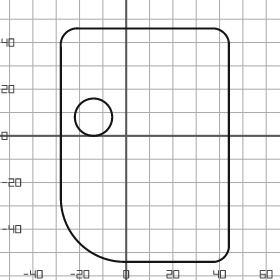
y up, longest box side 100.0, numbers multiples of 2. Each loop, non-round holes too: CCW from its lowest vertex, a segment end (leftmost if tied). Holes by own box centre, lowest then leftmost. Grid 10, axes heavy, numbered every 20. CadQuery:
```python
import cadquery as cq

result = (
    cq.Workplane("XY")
    .moveTo(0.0, -54.0)
    .lineTo(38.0, -54.0)
    .threePointArc((42.0, -52.0), (44.0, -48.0))
    .lineTo(44.0, 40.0)
    .threePointArc((42.0, 44.0), (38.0, 46.0))
    .lineTo(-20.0, 46.0)
    .threePointArc((-26.0, 44.0), (-28.0, 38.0))
    .lineTo(-28.0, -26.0)
    .threePointArc((-20.0, -46.0), (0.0, -54.0))
    .close()
    .moveTo(-14.0, 8.0)
    .circle(8.0)
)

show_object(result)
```